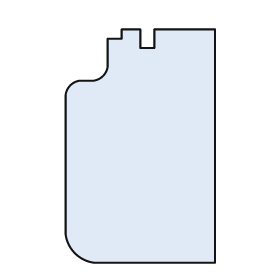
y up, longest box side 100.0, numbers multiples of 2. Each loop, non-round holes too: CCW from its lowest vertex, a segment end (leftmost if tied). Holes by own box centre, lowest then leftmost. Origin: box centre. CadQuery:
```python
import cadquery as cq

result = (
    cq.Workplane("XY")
    .moveTo(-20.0, -50.0)
    .lineTo(32.0, -50.0)
    .lineTo(32.0, 50.0)
    .lineTo(6.0, 50.0)
    .lineTo(6.0, 42.0)
    .lineTo(0.0, 42.0)
    .lineTo(0.0, 50.0)
    .lineTo(-8.0, 50.0)
    .lineTo(-8.0, 46.0)
    .lineTo(-14.0, 46.0)
    .lineTo(-14.0, 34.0)
    .threePointArc((-16.0, 30.0), (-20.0, 28.0))
    .lineTo(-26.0, 28.0)
    .threePointArc((-30.0, 26.0), (-32.0, 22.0))
    .lineTo(-32.0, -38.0)
    .threePointArc((-28.0, -46.0), (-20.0, -50.0))
    .close()
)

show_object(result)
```